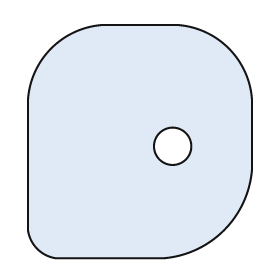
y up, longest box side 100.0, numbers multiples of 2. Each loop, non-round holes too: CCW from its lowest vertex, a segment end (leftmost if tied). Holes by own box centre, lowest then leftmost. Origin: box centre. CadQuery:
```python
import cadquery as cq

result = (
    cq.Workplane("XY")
    .moveTo(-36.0, -50.0)
    .lineTo(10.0, -50.0)
    .threePointArc((36.0, -38.0), (48.0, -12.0))
    .lineTo(48.0, 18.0)
    .threePointArc((38.0, 40.0), (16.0, 50.0))
    .lineTo(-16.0, 50.0)
    .threePointArc((-38.0, 40.0), (-48.0, 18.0))
    .lineTo(-48.0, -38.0)
    .threePointArc((-44.0, -46.0), (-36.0, -50.0))
    .close()
    .moveTo(14.0, -2.0)
    .circle(8.0)
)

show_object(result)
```